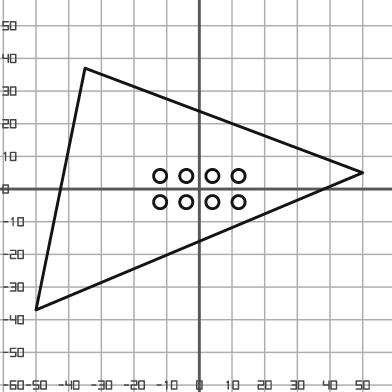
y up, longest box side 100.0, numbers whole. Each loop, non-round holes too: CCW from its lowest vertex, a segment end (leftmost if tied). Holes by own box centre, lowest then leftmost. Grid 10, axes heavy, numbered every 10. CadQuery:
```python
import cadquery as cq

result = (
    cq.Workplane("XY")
    .moveTo(-50.0, -37.0)
    .lineTo(50.0, 5.0)
    .lineTo(-35.0, 37.0)
    .close()
    .moveTo(-12.0, -4.0)
    .circle(2.0)
    .moveTo(-4.0, -4.0)
    .circle(2.0)
    .moveTo(4.0, -4.0)
    .circle(2.0)
    .moveTo(12.0, -4.0)
    .circle(2.0)
    .moveTo(-12.0, 4.0)
    .circle(2.0)
    .moveTo(-4.0, 4.0)
    .circle(2.0)
    .moveTo(4.0, 4.0)
    .circle(2.0)
    .moveTo(12.0, 4.0)
    .circle(2.0)
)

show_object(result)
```